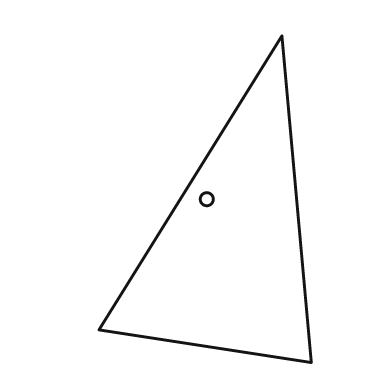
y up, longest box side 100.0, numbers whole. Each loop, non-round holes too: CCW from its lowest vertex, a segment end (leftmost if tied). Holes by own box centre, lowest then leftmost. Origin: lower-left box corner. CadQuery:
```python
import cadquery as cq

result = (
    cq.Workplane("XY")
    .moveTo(65.0, 0.0)
    .lineTo(56.0, 100.0)
    .lineTo(0.0, 10.0)
    .close()
    .moveTo(33.0, 50.0)
    .circle(2.0)
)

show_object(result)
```